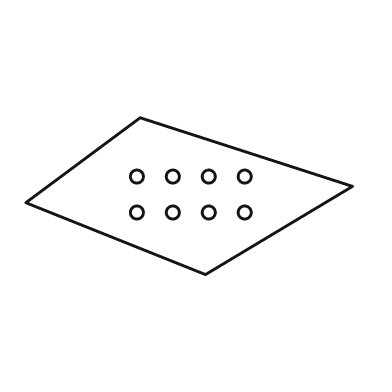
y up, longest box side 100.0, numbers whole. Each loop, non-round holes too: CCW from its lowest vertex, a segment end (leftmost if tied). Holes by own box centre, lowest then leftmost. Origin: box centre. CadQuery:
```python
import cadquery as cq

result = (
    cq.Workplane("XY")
    .moveTo(5.0, -24.0)
    .lineTo(50.0, 3.0)
    .lineTo(-15.0, 24.0)
    .lineTo(-50.0, -2.0)
    .close()
    .moveTo(-16.0, -5.0)
    .circle(2.0)
    .moveTo(-5.0, -5.0)
    .circle(2.0)
    .moveTo(6.0, -5.0)
    .circle(2.0)
    .moveTo(17.0, -5.0)
    .circle(2.0)
    .moveTo(-16.0, 6.0)
    .circle(2.0)
    .moveTo(-5.0, 6.0)
    .circle(2.0)
    .moveTo(6.0, 6.0)
    .circle(2.0)
    .moveTo(17.0, 6.0)
    .circle(2.0)
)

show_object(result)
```